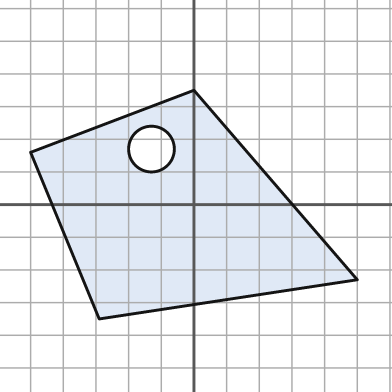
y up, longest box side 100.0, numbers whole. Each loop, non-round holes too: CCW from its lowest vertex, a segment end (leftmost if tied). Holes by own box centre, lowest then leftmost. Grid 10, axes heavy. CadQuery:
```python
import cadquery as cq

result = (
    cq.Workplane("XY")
    .moveTo(-29.0, -35.0)
    .lineTo(50.0, -23.0)
    .lineTo(0.0, 35.0)
    .lineTo(-50.0, 16.0)
    .close()
    .moveTo(-13.0, 17.0)
    .circle(7.0)
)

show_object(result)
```